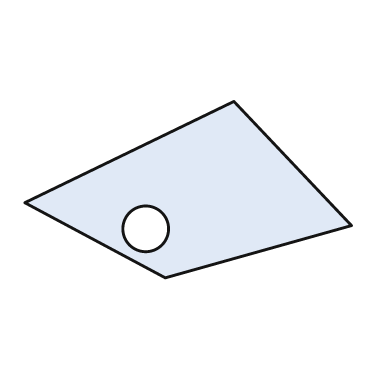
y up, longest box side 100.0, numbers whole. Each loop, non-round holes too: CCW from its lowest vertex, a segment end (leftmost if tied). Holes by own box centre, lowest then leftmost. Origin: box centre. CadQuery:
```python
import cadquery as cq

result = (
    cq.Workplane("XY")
    .moveTo(-7.0, -27.0)
    .lineTo(50.0, -11.0)
    .lineTo(14.0, 27.0)
    .lineTo(-50.0, -4.0)
    .close()
    .moveTo(-13.0, -12.0)
    .circle(7.0)
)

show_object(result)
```